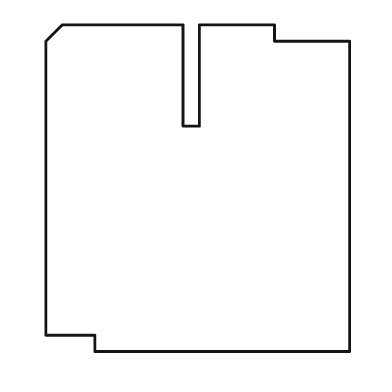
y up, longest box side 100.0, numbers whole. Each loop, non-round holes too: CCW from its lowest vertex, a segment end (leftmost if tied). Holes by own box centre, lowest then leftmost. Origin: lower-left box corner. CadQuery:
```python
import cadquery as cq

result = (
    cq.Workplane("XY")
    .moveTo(15.0, 0.0)
    .lineTo(93.0, 0.0)
    .lineTo(93.0, 95.0)
    .lineTo(70.0, 95.0)
    .lineTo(70.0, 100.0)
    .lineTo(47.0, 100.0)
    .lineTo(47.0, 69.0)
    .lineTo(42.0, 69.0)
    .lineTo(42.0, 100.0)
    .lineTo(5.0, 100.0)
    .lineTo(0.0, 95.0)
    .lineTo(0.0, 5.0)
    .lineTo(15.0, 5.0)
    .close()
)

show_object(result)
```